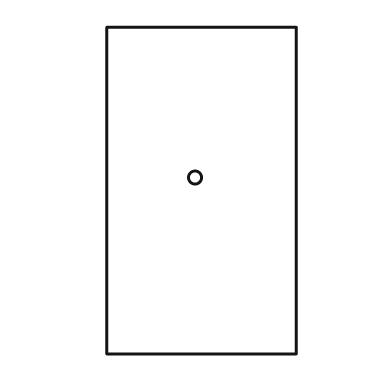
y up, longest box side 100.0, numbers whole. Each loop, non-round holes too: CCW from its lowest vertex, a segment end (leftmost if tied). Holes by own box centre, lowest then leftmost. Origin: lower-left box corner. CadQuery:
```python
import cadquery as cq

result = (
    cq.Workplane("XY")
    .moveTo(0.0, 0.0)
    .lineTo(58.0, 0.0)
    .lineTo(58.0, 100.0)
    .lineTo(0.0, 100.0)
    .close()
    .moveTo(27.0, 54.0)
    .circle(2.0)
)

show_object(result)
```